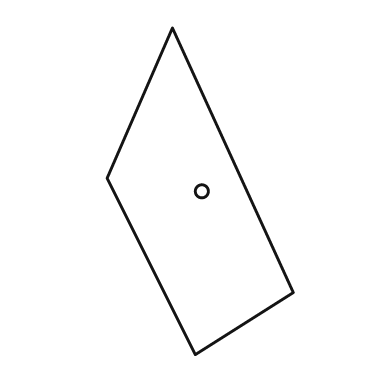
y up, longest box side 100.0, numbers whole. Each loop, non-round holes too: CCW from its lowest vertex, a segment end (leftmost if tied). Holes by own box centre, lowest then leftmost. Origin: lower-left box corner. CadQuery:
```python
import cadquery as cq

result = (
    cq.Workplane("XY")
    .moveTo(27.0, 0.0)
    .lineTo(57.0, 19.0)
    .lineTo(20.0, 100.0)
    .lineTo(0.0, 54.0)
    .close()
    .moveTo(29.0, 50.0)
    .circle(2.0)
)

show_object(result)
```